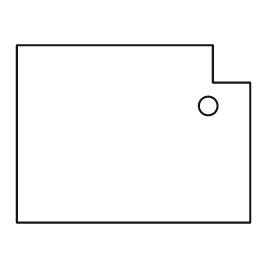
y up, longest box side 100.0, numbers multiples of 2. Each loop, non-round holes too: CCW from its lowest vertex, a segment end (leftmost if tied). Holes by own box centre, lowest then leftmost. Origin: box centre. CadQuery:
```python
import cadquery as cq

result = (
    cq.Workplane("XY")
    .moveTo(-50.0, -38.0)
    .lineTo(50.0, -38.0)
    .lineTo(50.0, 22.0)
    .lineTo(34.0, 22.0)
    .lineTo(34.0, 38.0)
    .lineTo(-50.0, 38.0)
    .close()
    .moveTo(32.0, 12.0)
    .circle(4.0)
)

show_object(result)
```